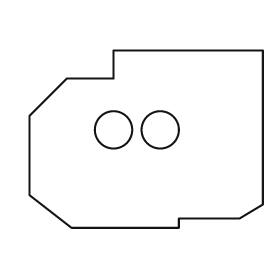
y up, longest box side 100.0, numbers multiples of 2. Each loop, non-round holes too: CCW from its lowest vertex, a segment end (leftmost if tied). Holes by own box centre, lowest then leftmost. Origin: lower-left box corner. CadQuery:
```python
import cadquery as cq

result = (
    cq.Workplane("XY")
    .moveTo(18.0, 0.0)
    .lineTo(64.0, 0.0)
    .lineTo(64.0, 4.0)
    .lineTo(90.0, 4.0)
    .lineTo(100.0, 10.0)
    .lineTo(100.0, 76.0)
    .lineTo(36.0, 76.0)
    .lineTo(36.0, 64.0)
    .lineTo(16.0, 64.0)
    .lineTo(0.0, 48.0)
    .lineTo(0.0, 14.0)
    .close()
    .moveTo(36.0, 42.0)
    .circle(8.0)
    .moveTo(56.0, 42.0)
    .circle(8.0)
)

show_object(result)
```